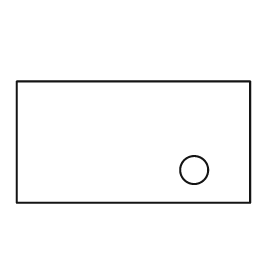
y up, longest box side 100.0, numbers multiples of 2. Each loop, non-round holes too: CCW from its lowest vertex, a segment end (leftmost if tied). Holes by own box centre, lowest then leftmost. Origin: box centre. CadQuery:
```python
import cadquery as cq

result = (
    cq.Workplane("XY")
    .moveTo(-50.0, -26.0)
    .lineTo(50.0, -26.0)
    .lineTo(50.0, 26.0)
    .lineTo(-50.0, 26.0)
    .close()
    .moveTo(26.0, -12.0)
    .circle(6.0)
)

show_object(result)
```